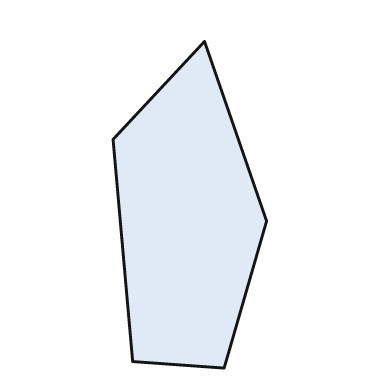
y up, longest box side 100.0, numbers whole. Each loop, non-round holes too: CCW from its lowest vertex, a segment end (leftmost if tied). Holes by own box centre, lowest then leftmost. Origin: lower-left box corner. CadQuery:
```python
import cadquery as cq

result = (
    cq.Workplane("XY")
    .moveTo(34.0, 0.0)
    .lineTo(47.0, 45.0)
    .lineTo(28.0, 100.0)
    .lineTo(0.0, 70.0)
    .lineTo(6.0, 2.0)
    .close()
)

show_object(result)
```